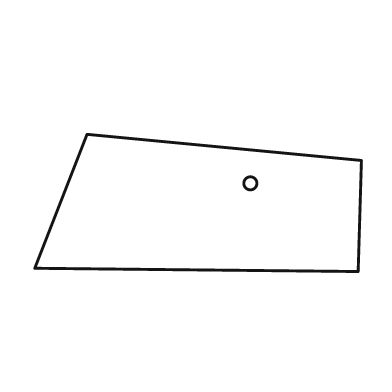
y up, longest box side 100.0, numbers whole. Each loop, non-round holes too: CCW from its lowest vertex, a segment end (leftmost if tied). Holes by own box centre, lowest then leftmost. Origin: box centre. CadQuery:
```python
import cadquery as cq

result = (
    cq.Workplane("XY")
    .moveTo(49.0, -21.0)
    .lineTo(50.0, 13.0)
    .lineTo(-34.0, 21.0)
    .lineTo(-50.0, -20.0)
    .close()
    .moveTo(16.0, 6.0)
    .circle(2.0)
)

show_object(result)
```